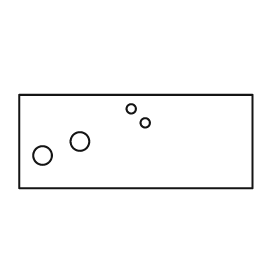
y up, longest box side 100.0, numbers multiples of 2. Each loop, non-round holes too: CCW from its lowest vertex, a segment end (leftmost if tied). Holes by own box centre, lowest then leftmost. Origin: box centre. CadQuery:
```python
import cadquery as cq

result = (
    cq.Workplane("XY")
    .moveTo(-50.0, -20.0)
    .lineTo(50.0, -20.0)
    .lineTo(50.0, 20.0)
    .lineTo(-50.0, 20.0)
    .close()
    .moveTo(-40.0, -6.0)
    .circle(4.0)
    .moveTo(-24.0, 0.0)
    .circle(4.0)
    .moveTo(4.0, 8.0)
    .circle(2.0)
    .moveTo(-2.0, 14.0)
    .circle(2.0)
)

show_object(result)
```